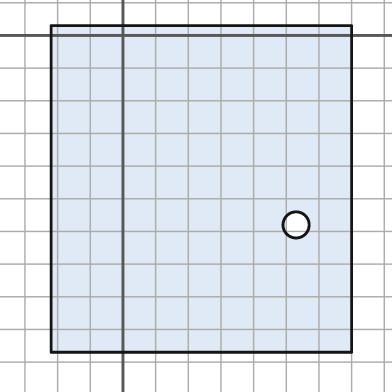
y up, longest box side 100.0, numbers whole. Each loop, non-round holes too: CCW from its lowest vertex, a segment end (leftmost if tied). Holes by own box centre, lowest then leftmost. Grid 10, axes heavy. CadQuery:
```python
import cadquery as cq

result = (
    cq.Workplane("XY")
    .moveTo(-22.0, -97.0)
    .lineTo(70.0, -97.0)
    .lineTo(70.0, 3.0)
    .lineTo(-22.0, 3.0)
    .close()
    .moveTo(53.0, -58.0)
    .circle(4.0)
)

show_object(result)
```